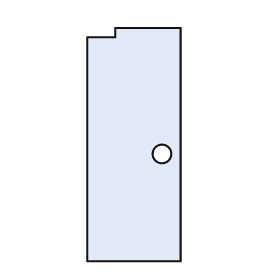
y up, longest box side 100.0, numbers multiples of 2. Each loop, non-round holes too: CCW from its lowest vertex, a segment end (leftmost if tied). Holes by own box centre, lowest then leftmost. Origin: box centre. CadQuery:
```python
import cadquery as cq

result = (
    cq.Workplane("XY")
    .moveTo(-20.0, -50.0)
    .lineTo(20.0, -50.0)
    .lineTo(20.0, 50.0)
    .lineTo(-8.0, 50.0)
    .lineTo(-8.0, 46.0)
    .lineTo(-20.0, 46.0)
    .close()
    .moveTo(12.0, -4.0)
    .circle(4.0)
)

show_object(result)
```